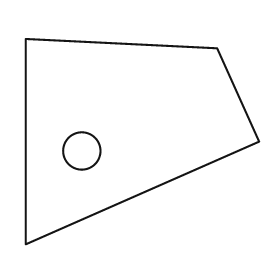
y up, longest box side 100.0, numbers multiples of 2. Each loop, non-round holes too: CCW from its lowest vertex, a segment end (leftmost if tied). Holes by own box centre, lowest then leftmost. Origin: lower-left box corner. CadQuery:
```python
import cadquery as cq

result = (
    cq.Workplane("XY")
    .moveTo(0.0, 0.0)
    .lineTo(100.0, 44.0)
    .lineTo(82.0, 84.0)
    .lineTo(0.0, 88.0)
    .close()
    .moveTo(24.0, 40.0)
    .circle(8.0)
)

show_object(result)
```